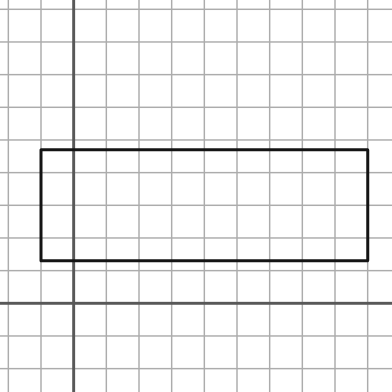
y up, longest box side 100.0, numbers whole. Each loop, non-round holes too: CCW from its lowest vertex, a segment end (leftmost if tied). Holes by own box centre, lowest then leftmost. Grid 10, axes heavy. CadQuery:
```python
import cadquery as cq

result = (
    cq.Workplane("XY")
    .moveTo(-10.0, 13.0)
    .lineTo(90.0, 13.0)
    .lineTo(90.0, 47.0)
    .lineTo(-10.0, 47.0)
    .close()
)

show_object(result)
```